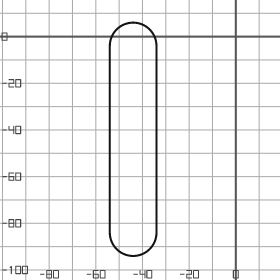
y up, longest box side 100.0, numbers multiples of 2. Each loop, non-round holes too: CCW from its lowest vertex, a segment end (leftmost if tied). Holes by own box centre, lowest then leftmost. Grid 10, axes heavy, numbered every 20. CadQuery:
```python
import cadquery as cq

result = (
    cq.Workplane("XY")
    .moveTo(-54.0, -84.0)
    .threePointArc((-44.0, -94.0), (-34.0, -84.0))
    .lineTo(-34.0, -4.0)
    .threePointArc((-44.0, 6.0), (-54.0, -4.0))
    .close()
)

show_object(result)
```